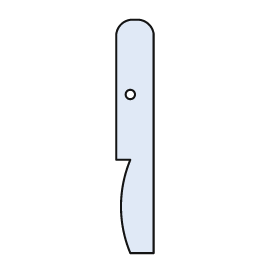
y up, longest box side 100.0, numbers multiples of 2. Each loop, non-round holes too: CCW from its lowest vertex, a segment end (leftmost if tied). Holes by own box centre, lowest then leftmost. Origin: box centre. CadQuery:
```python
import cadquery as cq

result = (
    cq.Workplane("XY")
    .moveTo(-2.0, -50.0)
    .lineTo(8.0, -50.0)
    .lineTo(8.0, 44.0)
    .threePointArc((6.0, 48.0), (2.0, 50.0))
    .lineTo(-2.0, 50.0)
    .threePointArc((-6.0, 48.0), (-8.0, 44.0))
    .lineTo(-8.0, -10.0)
    .lineTo(-2.0, -10.0)
    .threePointArc((-6.0, -30.0), (-2.0, -50.0))
    .close()
    .moveTo(-2.0, 18.0)
    .circle(2.0)
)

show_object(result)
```